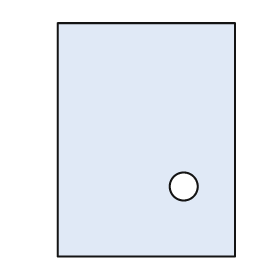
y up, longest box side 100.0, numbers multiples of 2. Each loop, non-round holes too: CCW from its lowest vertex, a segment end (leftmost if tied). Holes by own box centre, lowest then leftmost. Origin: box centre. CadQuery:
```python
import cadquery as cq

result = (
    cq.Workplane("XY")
    .moveTo(-38.0, -50.0)
    .lineTo(38.0, -50.0)
    .lineTo(38.0, 50.0)
    .lineTo(-38.0, 50.0)
    .close()
    .moveTo(16.0, -20.0)
    .circle(6.0)
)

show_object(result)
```